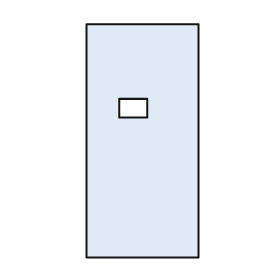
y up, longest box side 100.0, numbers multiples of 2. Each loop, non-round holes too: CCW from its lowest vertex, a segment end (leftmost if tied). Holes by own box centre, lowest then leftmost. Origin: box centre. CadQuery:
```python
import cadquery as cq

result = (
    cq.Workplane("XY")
    .moveTo(-24.0, -50.0)
    .lineTo(24.0, -50.0)
    .lineTo(24.0, 50.0)
    .lineTo(-24.0, 50.0)
    .close()
    .moveTo(-10.0, 10.0)
    .lineTo(2.0, 10.0)
    .lineTo(2.0, 18.0)
    .lineTo(-10.0, 18.0)
    .close()
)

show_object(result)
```